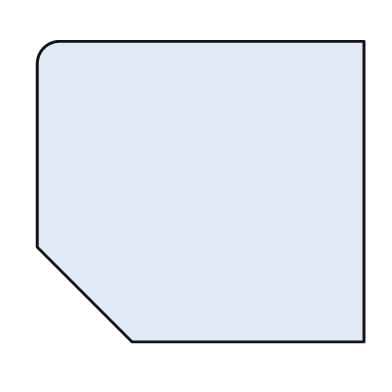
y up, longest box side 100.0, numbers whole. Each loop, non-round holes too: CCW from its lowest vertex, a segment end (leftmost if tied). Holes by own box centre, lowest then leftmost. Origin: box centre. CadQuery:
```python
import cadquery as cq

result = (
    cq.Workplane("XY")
    .moveTo(-21.0, -46.0)
    .lineTo(50.0, -46.0)
    .lineTo(50.0, 46.0)
    .lineTo(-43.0, 46.0)
    .threePointArc((-48.0, 44.0), (-50.0, 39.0))
    .lineTo(-50.0, -17.0)
    .close()
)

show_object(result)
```